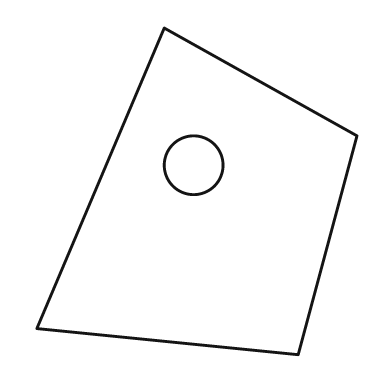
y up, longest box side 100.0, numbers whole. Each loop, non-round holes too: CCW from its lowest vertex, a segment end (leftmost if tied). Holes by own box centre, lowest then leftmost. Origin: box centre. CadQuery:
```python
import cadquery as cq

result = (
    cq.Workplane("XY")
    .moveTo(31.0, -50.0)
    .lineTo(49.0, 17.0)
    .lineTo(-10.0, 50.0)
    .lineTo(-49.0, -42.0)
    .close()
    .moveTo(-1.0, 8.0)
    .circle(9.0)
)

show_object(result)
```